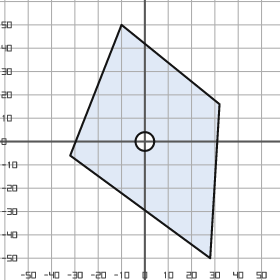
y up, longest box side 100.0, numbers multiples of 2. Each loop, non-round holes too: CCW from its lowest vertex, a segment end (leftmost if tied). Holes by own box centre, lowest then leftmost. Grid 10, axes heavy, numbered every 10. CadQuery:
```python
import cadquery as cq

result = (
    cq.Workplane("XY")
    .moveTo(28.0, -50.0)
    .lineTo(32.0, 16.0)
    .lineTo(-10.0, 50.0)
    .lineTo(-32.0, -6.0)
    .close()
    .moveTo(0.0, 0.0)
    .circle(4.0)
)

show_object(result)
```